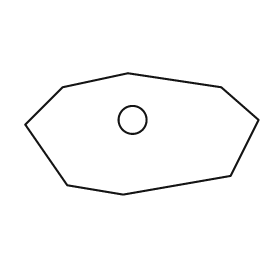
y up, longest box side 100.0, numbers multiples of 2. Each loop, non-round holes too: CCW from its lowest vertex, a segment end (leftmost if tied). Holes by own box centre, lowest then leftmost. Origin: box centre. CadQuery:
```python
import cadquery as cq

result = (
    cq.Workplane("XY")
    .moveTo(-8.0, -26.0)
    .lineTo(38.0, -18.0)
    .lineTo(50.0, 6.0)
    .lineTo(34.0, 20.0)
    .lineTo(-6.0, 26.0)
    .lineTo(-34.0, 20.0)
    .lineTo(-50.0, 4.0)
    .lineTo(-32.0, -22.0)
    .close()
    .moveTo(-4.0, 6.0)
    .circle(6.0)
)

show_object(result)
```